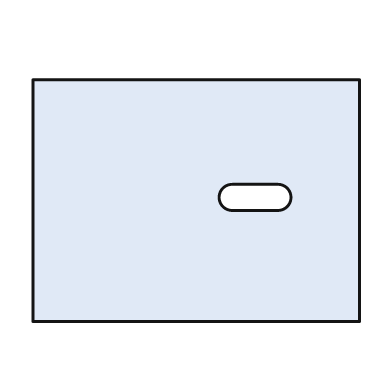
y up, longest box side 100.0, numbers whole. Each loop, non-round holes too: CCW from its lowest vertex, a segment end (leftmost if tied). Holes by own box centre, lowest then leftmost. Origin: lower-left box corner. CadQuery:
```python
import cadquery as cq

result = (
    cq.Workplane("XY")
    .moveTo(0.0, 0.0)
    .lineTo(100.0, 0.0)
    .lineTo(100.0, 74.0)
    .lineTo(0.0, 74.0)
    .close()
    .moveTo(61.0, 34.0)
    .lineTo(75.0, 34.0)
    .threePointArc((79.0, 38.0), (75.0, 42.0))
    .lineTo(61.0, 42.0)
    .threePointArc((57.0, 38.0), (61.0, 34.0))
    .close()
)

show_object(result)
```